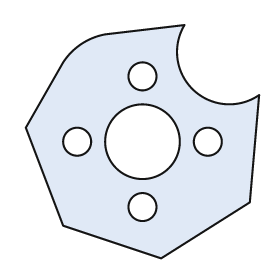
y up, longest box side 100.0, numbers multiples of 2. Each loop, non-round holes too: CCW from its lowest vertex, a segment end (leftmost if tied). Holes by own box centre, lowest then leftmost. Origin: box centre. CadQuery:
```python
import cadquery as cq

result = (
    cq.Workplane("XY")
    .moveTo(8.0, -50.0)
    .lineTo(46.0, -26.0)
    .lineTo(50.0, 20.0)
    .threePointArc((22.0, 22.0), (18.0, 50.0))
    .lineTo(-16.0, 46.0)
    .threePointArc((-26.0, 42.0), (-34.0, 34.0))
    .lineTo(-50.0, 6.0)
    .lineTo(-34.0, -36.0)
    .close()
    .moveTo(0.0, -28.0)
    .circle(6.0)
    .moveTo(-28.0, 0.0)
    .circle(6.0)
    .moveTo(0.0, 0.0)
    .circle(16.0)
    .moveTo(28.0, 0.0)
    .circle(6.0)
    .moveTo(0.0, 28.0)
    .circle(6.0)
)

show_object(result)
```